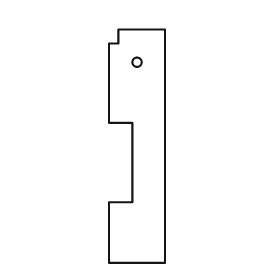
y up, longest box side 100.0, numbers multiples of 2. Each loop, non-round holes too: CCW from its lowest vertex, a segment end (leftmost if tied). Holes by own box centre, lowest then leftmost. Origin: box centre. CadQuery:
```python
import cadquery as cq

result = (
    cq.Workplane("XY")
    .moveTo(-12.0, -50.0)
    .lineTo(12.0, -50.0)
    .lineTo(12.0, 50.0)
    .lineTo(-8.0, 50.0)
    .lineTo(-8.0, 44.0)
    .lineTo(-12.0, 44.0)
    .lineTo(-12.0, 10.0)
    .lineTo(-2.0, 10.0)
    .lineTo(-2.0, -24.0)
    .lineTo(-12.0, -24.0)
    .close()
    .moveTo(0.0, 36.0)
    .circle(2.0)
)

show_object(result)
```